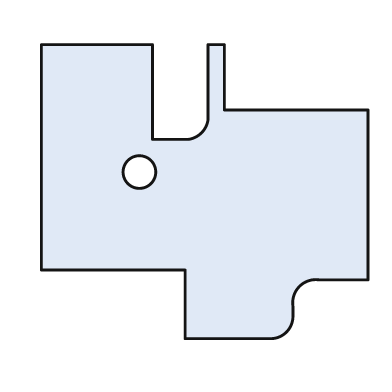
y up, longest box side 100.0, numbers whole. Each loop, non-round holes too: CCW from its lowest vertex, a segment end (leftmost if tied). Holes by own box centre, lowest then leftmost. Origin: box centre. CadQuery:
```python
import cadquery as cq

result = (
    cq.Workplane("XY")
    .moveTo(-6.0, -45.0)
    .lineTo(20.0, -45.0)
    .threePointArc((25.0, -43.0), (27.0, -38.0))
    .lineTo(27.0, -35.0)
    .threePointArc((29.0, -29.0), (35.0, -27.0))
    .lineTo(50.0, -27.0)
    .lineTo(50.0, 25.0)
    .lineTo(6.0, 25.0)
    .lineTo(6.0, 45.0)
    .lineTo(1.0, 45.0)
    .lineTo(1.0, 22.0)
    .threePointArc((-1.0, 18.0), (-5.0, 16.0))
    .lineTo(-16.0, 16.0)
    .lineTo(-16.0, 45.0)
    .lineTo(-50.0, 45.0)
    .lineTo(-50.0, -24.0)
    .lineTo(-6.0, -24.0)
    .close()
    .moveTo(-20.0, 6.0)
    .circle(5.0)
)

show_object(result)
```